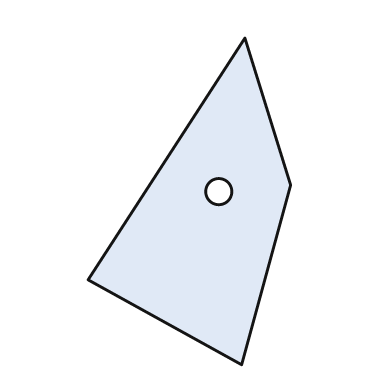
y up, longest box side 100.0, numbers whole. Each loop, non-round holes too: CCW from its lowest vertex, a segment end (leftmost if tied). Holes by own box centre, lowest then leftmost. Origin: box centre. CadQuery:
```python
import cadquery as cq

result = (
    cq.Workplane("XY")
    .moveTo(16.0, -50.0)
    .lineTo(31.0, 5.0)
    .lineTo(17.0, 50.0)
    .lineTo(-31.0, -24.0)
    .close()
    .moveTo(9.0, 3.0)
    .circle(4.0)
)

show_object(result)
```